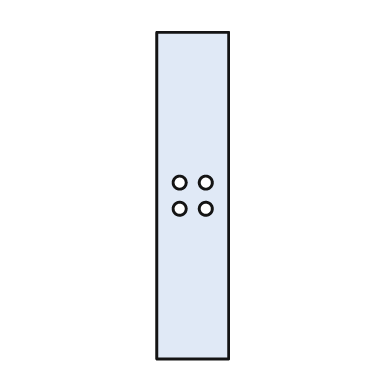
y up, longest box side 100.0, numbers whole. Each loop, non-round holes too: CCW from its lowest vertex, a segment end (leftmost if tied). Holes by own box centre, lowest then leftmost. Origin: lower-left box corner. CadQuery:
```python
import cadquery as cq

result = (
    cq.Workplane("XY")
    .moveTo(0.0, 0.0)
    .lineTo(22.0, 0.0)
    .lineTo(22.0, 100.0)
    .lineTo(0.0, 100.0)
    .close()
    .moveTo(7.0, 46.0)
    .circle(2.0)
    .moveTo(15.0, 46.0)
    .circle(2.0)
    .moveTo(7.0, 54.0)
    .circle(2.0)
    .moveTo(15.0, 54.0)
    .circle(2.0)
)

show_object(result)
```